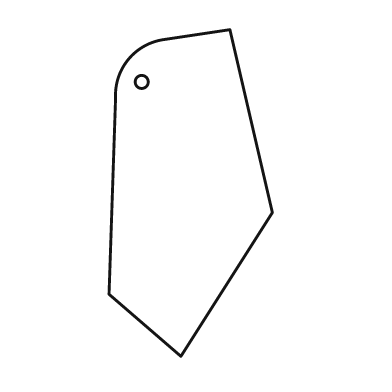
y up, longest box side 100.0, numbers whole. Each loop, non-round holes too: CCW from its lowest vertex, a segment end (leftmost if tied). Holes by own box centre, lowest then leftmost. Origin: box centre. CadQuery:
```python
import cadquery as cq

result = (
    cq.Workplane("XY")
    .moveTo(-3.0, -50.0)
    .lineTo(25.0, -6.0)
    .lineTo(12.0, 50.0)
    .lineTo(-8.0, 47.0)
    .threePointArc((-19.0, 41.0), (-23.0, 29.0))
    .lineTo(-25.0, -31.0)
    .close()
    .moveTo(-15.0, 34.0)
    .circle(2.0)
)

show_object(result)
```